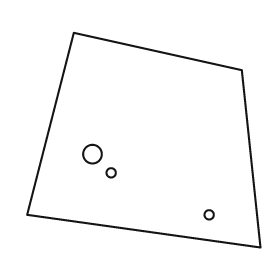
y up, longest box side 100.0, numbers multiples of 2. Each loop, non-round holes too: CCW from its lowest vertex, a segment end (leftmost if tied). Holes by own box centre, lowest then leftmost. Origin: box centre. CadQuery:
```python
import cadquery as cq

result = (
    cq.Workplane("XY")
    .moveTo(50.0, -46.0)
    .lineTo(42.0, 30.0)
    .lineTo(-30.0, 46.0)
    .lineTo(-50.0, -32.0)
    .close()
    .moveTo(28.0, -32.0)
    .circle(2.0)
    .moveTo(-14.0, -14.0)
    .circle(2.0)
    .moveTo(-22.0, -6.0)
    .circle(4.0)
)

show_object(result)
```